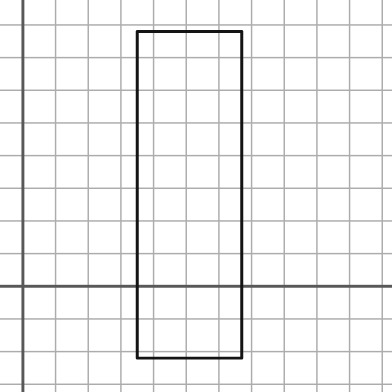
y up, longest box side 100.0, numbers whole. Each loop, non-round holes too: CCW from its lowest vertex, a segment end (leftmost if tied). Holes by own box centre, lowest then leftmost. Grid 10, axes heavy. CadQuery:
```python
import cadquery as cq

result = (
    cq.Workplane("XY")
    .moveTo(35.0, -22.0)
    .lineTo(67.0, -22.0)
    .lineTo(67.0, 78.0)
    .lineTo(35.0, 78.0)
    .close()
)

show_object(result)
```